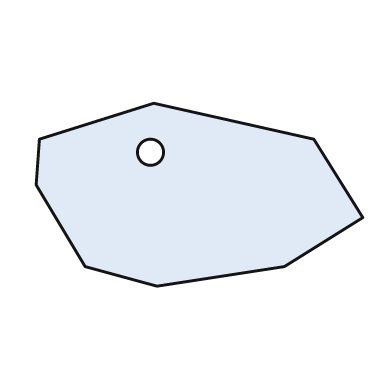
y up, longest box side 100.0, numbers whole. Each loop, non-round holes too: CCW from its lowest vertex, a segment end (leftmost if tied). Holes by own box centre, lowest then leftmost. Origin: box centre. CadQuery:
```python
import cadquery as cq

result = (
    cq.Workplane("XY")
    .moveTo(-13.0, -28.0)
    .lineTo(26.0, -22.0)
    .lineTo(50.0, -7.0)
    .lineTo(35.0, 17.0)
    .lineTo(-14.0, 28.0)
    .lineTo(-49.0, 17.0)
    .lineTo(-50.0, 3.0)
    .lineTo(-35.0, -22.0)
    .close()
    .moveTo(-15.0, 13.0)
    .circle(4.0)
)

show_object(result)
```